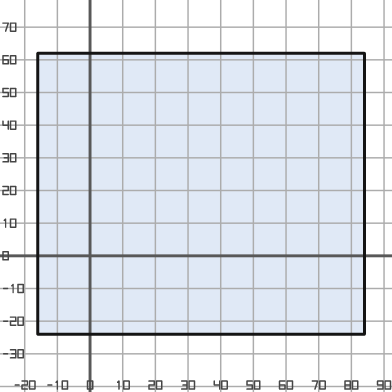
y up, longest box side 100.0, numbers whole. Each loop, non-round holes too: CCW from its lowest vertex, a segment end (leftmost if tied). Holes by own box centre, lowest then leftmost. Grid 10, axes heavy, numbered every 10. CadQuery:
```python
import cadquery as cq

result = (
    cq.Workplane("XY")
    .moveTo(-16.0, -24.0)
    .lineTo(84.0, -24.0)
    .lineTo(84.0, 62.0)
    .lineTo(-16.0, 62.0)
    .close()
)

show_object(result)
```